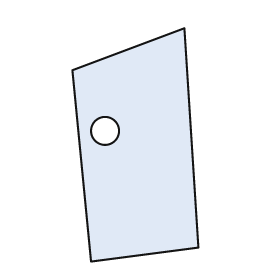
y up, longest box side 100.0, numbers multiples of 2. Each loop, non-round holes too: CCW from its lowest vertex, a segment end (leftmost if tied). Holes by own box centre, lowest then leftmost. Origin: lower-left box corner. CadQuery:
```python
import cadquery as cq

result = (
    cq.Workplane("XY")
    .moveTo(8.0, 0.0)
    .lineTo(54.0, 6.0)
    .lineTo(48.0, 100.0)
    .lineTo(0.0, 82.0)
    .close()
    .moveTo(14.0, 56.0)
    .circle(6.0)
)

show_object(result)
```